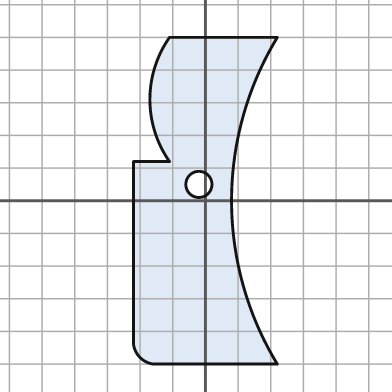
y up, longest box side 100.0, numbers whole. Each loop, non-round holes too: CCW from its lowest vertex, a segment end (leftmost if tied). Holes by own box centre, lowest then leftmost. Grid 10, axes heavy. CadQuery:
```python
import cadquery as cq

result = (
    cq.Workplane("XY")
    .moveTo(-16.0, -50.0)
    .lineTo(22.0, -50.0)
    .threePointArc((8.0, 0.0), (22.0, 50.0))
    .lineTo(-11.0, 50.0)
    .threePointArc((-17.0, 31.0), (-11.0, 12.0))
    .lineTo(-22.0, 12.0)
    .lineTo(-22.0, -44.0)
    .threePointArc((-20.0, -48.0), (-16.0, -50.0))
    .close()
    .moveTo(-2.0, 5.0)
    .circle(4.0)
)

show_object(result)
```